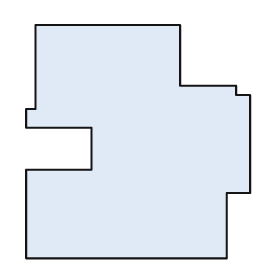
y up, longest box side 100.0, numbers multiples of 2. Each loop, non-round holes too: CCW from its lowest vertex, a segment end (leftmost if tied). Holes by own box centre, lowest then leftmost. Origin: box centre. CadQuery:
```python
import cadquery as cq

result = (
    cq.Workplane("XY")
    .moveTo(-48.0, -50.0)
    .lineTo(38.0, -50.0)
    .lineTo(38.0, -22.0)
    .lineTo(48.0, -22.0)
    .lineTo(48.0, 20.0)
    .lineTo(42.0, 20.0)
    .lineTo(42.0, 24.0)
    .lineTo(18.0, 24.0)
    .lineTo(18.0, 50.0)
    .lineTo(-44.0, 50.0)
    .lineTo(-44.0, 14.0)
    .lineTo(-48.0, 14.0)
    .lineTo(-48.0, 6.0)
    .lineTo(-20.0, 6.0)
    .lineTo(-20.0, -12.0)
    .lineTo(-48.0, -12.0)
    .close()
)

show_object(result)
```